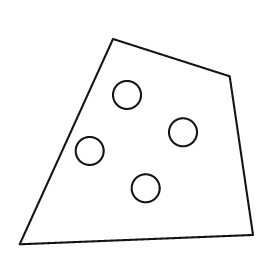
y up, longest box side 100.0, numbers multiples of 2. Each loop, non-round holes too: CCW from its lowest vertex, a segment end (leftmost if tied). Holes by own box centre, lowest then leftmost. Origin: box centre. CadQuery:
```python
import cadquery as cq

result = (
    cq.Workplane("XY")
    .moveTo(-50.0, -44.0)
    .lineTo(50.0, -40.0)
    .lineTo(40.0, 28.0)
    .lineTo(-10.0, 44.0)
    .close()
    .moveTo(4.0, -20.0)
    .circle(6.0)
    .moveTo(-20.0, -4.0)
    .circle(6.0)
    .moveTo(20.0, 4.0)
    .circle(6.0)
    .moveTo(-4.0, 20.0)
    .circle(6.0)
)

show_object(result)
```